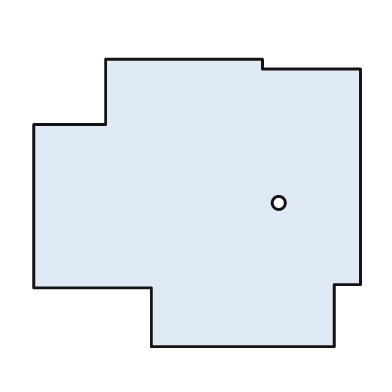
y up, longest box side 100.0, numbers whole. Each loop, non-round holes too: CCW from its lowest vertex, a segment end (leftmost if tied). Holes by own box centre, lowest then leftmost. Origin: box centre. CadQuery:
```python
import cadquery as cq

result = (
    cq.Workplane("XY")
    .moveTo(-14.0, -44.0)
    .lineTo(42.0, -44.0)
    .lineTo(42.0, -25.0)
    .lineTo(50.0, -25.0)
    .lineTo(50.0, 41.0)
    .lineTo(20.0, 41.0)
    .lineTo(20.0, 44.0)
    .lineTo(-28.0, 44.0)
    .lineTo(-28.0, 24.0)
    .lineTo(-50.0, 24.0)
    .lineTo(-50.0, -26.0)
    .lineTo(-14.0, -26.0)
    .close()
    .moveTo(25.0, 0.0)
    .circle(2.0)
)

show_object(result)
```